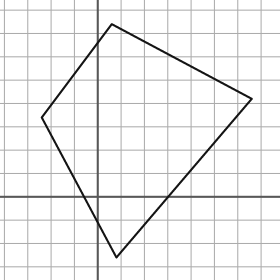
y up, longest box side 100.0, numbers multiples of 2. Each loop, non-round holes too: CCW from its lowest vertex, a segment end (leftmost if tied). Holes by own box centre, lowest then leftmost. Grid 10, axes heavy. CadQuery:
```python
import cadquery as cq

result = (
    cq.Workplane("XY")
    .moveTo(8.0, -26.0)
    .lineTo(66.0, 42.0)
    .lineTo(6.0, 74.0)
    .lineTo(-24.0, 34.0)
    .close()
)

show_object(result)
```